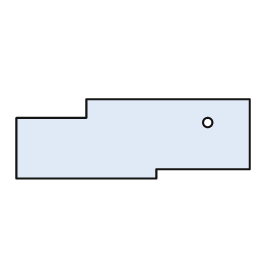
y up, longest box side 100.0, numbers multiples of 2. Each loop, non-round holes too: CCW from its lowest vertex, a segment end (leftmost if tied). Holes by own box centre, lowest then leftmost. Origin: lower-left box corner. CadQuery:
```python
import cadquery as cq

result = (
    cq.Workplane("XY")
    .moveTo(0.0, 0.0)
    .lineTo(60.0, 0.0)
    .lineTo(60.0, 4.0)
    .lineTo(100.0, 4.0)
    .lineTo(100.0, 34.0)
    .lineTo(30.0, 34.0)
    .lineTo(30.0, 26.0)
    .lineTo(0.0, 26.0)
    .close()
    .moveTo(82.0, 24.0)
    .circle(2.0)
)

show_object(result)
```